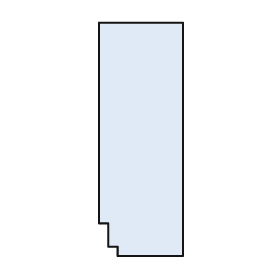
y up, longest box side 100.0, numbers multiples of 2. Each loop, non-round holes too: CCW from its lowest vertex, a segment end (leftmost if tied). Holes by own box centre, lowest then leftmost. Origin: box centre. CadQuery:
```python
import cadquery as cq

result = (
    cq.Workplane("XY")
    .moveTo(-10.0, -50.0)
    .lineTo(18.0, -50.0)
    .lineTo(18.0, 50.0)
    .lineTo(-18.0, 50.0)
    .lineTo(-18.0, -36.0)
    .lineTo(-14.0, -36.0)
    .lineTo(-14.0, -46.0)
    .lineTo(-10.0, -46.0)
    .close()
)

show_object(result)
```